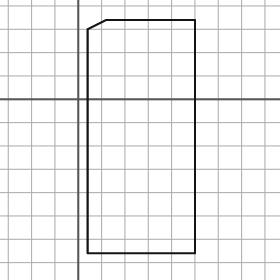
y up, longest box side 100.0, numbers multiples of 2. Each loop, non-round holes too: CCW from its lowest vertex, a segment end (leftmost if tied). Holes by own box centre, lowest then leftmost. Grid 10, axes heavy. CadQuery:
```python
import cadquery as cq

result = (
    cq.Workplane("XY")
    .moveTo(4.0, -66.0)
    .lineTo(50.0, -66.0)
    .lineTo(50.0, 34.0)
    .lineTo(12.0, 34.0)
    .lineTo(4.0, 30.0)
    .close()
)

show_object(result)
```